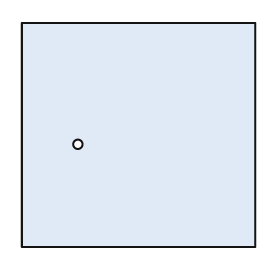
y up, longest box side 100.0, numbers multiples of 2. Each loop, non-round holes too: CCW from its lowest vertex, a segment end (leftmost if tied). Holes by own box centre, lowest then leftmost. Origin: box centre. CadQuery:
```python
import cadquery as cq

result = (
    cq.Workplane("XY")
    .moveTo(-50.0, -48.0)
    .lineTo(50.0, -48.0)
    .lineTo(50.0, 48.0)
    .lineTo(-50.0, 48.0)
    .close()
    .moveTo(-26.0, -4.0)
    .circle(2.0)
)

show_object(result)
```